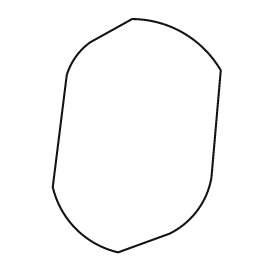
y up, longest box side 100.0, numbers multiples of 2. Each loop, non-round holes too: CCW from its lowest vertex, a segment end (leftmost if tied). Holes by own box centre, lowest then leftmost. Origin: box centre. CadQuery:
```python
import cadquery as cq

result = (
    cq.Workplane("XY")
    .moveTo(-8.0, -50.0)
    .lineTo(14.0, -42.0)
    .threePointArc((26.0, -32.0), (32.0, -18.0))
    .lineTo(36.0, 28.0)
    .threePointArc((20.0, 44.0), (-2.0, 50.0))
    .lineTo(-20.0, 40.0)
    .threePointArc((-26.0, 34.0), (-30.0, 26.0))
    .lineTo(-36.0, -22.0)
    .threePointArc((-26.0, -40.0), (-8.0, -50.0))
    .close()
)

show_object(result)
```